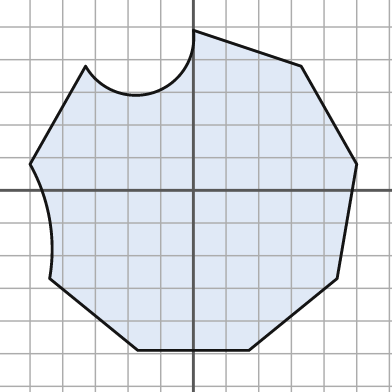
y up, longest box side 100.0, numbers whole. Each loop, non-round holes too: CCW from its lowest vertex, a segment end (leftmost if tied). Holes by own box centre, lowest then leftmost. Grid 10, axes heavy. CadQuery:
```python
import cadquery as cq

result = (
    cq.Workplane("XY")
    .moveTo(-17.0, -49.0)
    .lineTo(17.0, -49.0)
    .lineTo(44.0, -27.0)
    .lineTo(50.0, 8.0)
    .lineTo(33.0, 38.0)
    .lineTo(0.0, 49.0)
    .threePointArc((-12.0, 30.0), (-33.0, 38.0))
    .lineTo(-50.0, 8.0)
    .threePointArc((-44.0, -9.0), (-44.0, -27.0))
    .close()
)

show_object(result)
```